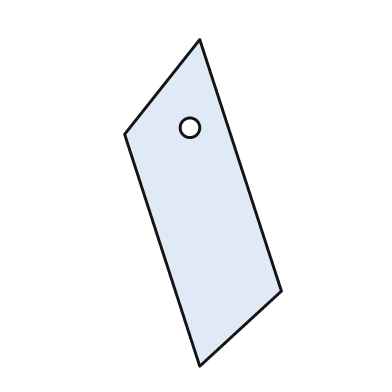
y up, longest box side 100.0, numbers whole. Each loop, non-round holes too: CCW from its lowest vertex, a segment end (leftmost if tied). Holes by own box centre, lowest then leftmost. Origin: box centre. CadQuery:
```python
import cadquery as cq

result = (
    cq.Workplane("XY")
    .moveTo(-1.0, -50.0)
    .lineTo(24.0, -27.0)
    .lineTo(-1.0, 50.0)
    .lineTo(-24.0, 21.0)
    .close()
    .moveTo(-4.0, 23.0)
    .circle(3.0)
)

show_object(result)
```